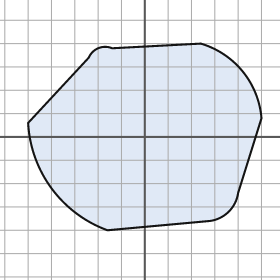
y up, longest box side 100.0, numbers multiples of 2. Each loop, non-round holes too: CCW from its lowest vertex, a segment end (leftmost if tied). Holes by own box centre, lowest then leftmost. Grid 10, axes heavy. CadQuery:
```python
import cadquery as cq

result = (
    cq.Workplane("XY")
    .moveTo(-16.0, -40.0)
    .lineTo(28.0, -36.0)
    .threePointArc((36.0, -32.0), (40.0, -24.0))
    .lineTo(50.0, 8.0)
    .threePointArc((42.0, 28.0), (24.0, 40.0))
    .lineTo(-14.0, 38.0)
    .threePointArc((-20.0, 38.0), (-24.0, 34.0))
    .lineTo(-50.0, 6.0)
    .threePointArc((-40.0, -22.0), (-16.0, -40.0))
    .close()
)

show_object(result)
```